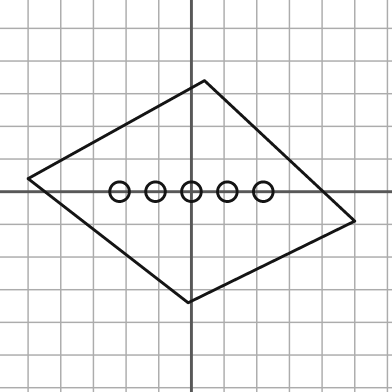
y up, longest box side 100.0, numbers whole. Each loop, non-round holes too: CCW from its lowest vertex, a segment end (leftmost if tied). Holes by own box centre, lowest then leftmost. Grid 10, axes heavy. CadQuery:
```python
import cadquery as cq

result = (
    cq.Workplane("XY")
    .moveTo(-1.0, -34.0)
    .lineTo(50.0, -9.0)
    .lineTo(4.0, 34.0)
    .lineTo(-50.0, 4.0)
    .close()
    .moveTo(-22.0, 0.0)
    .circle(3.0)
    .moveTo(-11.0, 0.0)
    .circle(3.0)
    .moveTo(0.0, 0.0)
    .circle(3.0)
    .moveTo(11.0, 0.0)
    .circle(3.0)
    .moveTo(22.0, 0.0)
    .circle(3.0)
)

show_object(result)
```